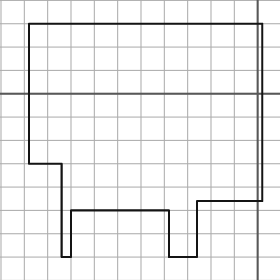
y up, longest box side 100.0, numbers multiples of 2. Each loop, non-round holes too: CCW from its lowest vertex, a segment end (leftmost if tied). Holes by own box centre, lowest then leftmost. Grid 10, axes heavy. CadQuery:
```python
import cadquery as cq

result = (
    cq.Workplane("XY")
    .moveTo(-84.0, -70.0)
    .lineTo(-80.0, -70.0)
    .lineTo(-80.0, -50.0)
    .lineTo(-38.0, -50.0)
    .lineTo(-38.0, -70.0)
    .lineTo(-26.0, -70.0)
    .lineTo(-26.0, -46.0)
    .lineTo(2.0, -46.0)
    .lineTo(2.0, 30.0)
    .lineTo(-98.0, 30.0)
    .lineTo(-98.0, -30.0)
    .lineTo(-84.0, -30.0)
    .close()
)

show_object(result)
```